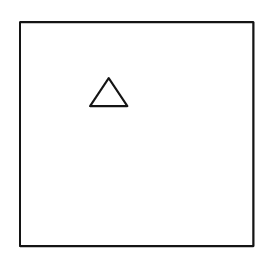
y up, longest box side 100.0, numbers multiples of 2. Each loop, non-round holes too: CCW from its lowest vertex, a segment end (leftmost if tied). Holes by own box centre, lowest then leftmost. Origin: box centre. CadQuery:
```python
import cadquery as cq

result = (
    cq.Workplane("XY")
    .moveTo(-50.0, -48.0)
    .lineTo(50.0, -48.0)
    .lineTo(50.0, 48.0)
    .lineTo(-50.0, 48.0)
    .close()
    .moveTo(-20.0, 12.0)
    .lineTo(-4.0, 12.0)
    .lineTo(-12.0, 24.0)
    .close()
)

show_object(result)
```